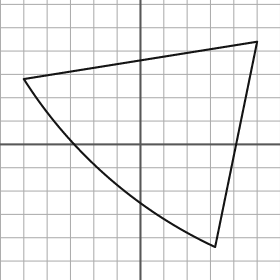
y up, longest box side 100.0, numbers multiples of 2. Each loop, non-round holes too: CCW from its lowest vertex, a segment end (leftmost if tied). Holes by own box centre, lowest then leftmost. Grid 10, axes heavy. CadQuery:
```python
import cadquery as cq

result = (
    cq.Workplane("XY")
    .moveTo(32.0, -44.0)
    .lineTo(50.0, 44.0)
    .lineTo(-50.0, 28.0)
    .threePointArc((-14.0, -14.0), (32.0, -44.0))
    .close()
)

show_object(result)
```